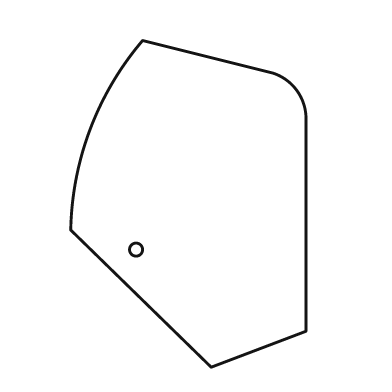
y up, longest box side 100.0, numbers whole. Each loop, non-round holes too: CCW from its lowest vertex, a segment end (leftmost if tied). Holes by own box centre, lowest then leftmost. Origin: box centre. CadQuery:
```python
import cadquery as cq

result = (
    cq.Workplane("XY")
    .moveTo(7.0, -50.0)
    .lineTo(36.0, -39.0)
    .lineTo(36.0, 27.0)
    .threePointArc((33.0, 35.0), (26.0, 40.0))
    .lineTo(-14.0, 50.0)
    .threePointArc((-30.0, 23.0), (-36.0, -8.0))
    .close()
    .moveTo(-16.0, -14.0)
    .circle(2.0)
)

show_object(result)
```